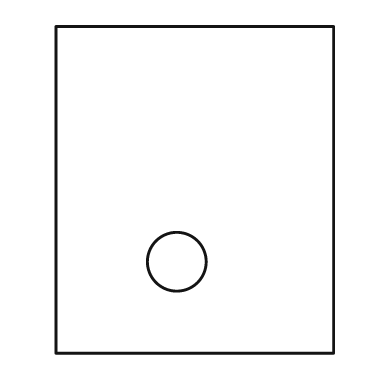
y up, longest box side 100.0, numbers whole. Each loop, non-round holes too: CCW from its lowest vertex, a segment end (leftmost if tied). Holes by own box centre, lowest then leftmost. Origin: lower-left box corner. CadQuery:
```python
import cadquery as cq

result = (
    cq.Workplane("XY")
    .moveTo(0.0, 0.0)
    .lineTo(85.0, 0.0)
    .lineTo(85.0, 100.0)
    .lineTo(0.0, 100.0)
    .close()
    .moveTo(37.0, 28.0)
    .circle(9.0)
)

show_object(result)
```